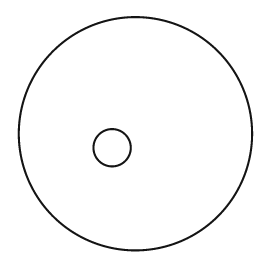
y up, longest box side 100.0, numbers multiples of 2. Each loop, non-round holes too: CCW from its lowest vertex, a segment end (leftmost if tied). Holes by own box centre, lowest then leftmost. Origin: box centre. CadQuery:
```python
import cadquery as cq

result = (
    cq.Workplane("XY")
    .moveTo(0.0, 0.0)
    .circle(50.0)
    .moveTo(-10.0, -6.0)
    .circle(8.0)
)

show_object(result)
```